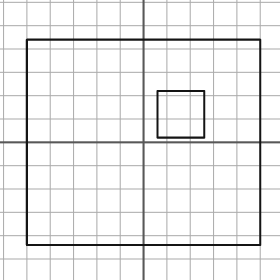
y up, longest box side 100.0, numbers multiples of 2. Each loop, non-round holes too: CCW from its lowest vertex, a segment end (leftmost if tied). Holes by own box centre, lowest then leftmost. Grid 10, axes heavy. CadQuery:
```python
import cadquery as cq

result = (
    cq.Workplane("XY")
    .moveTo(-50.0, -44.0)
    .lineTo(50.0, -44.0)
    .lineTo(50.0, 44.0)
    .lineTo(-50.0, 44.0)
    .close()
    .moveTo(6.0, 2.0)
    .lineTo(26.0, 2.0)
    .lineTo(26.0, 22.0)
    .lineTo(6.0, 22.0)
    .close()
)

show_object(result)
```